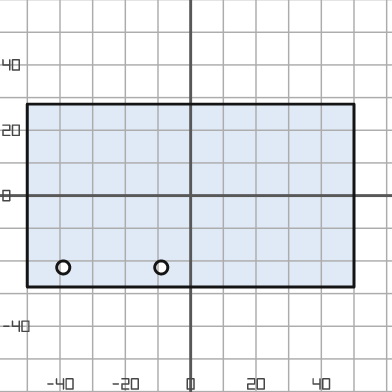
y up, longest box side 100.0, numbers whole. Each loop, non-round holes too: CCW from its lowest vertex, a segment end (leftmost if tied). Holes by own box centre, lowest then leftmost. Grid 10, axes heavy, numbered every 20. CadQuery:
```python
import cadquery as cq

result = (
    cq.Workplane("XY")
    .moveTo(-50.0, -28.0)
    .lineTo(50.0, -28.0)
    .lineTo(50.0, 28.0)
    .lineTo(-50.0, 28.0)
    .close()
    .moveTo(-39.0, -22.0)
    .circle(2.0)
    .moveTo(-9.0, -22.0)
    .circle(2.0)
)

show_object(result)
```